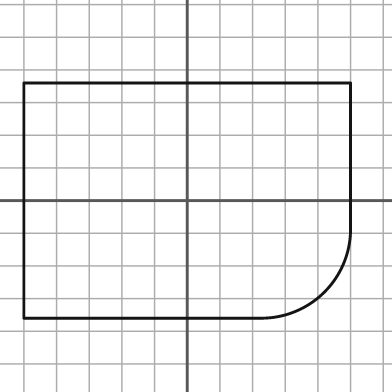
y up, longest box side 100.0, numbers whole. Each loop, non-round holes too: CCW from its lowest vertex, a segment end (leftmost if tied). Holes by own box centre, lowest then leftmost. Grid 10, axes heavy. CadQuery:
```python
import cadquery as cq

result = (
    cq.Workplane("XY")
    .moveTo(-50.0, -36.0)
    .lineTo(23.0, -36.0)
    .threePointArc((42.0, -28.0), (50.0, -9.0))
    .lineTo(50.0, 36.0)
    .lineTo(-50.0, 36.0)
    .close()
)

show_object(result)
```